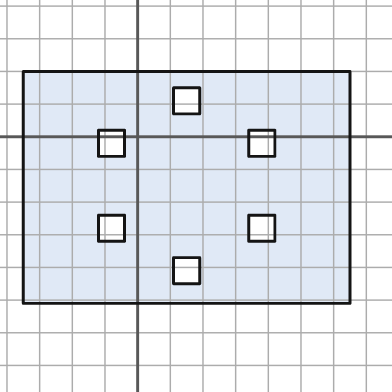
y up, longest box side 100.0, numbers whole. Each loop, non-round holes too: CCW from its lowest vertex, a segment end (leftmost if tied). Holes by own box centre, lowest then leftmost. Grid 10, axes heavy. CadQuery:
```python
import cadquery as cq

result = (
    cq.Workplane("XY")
    .moveTo(-35.0, -51.0)
    .lineTo(65.0, -51.0)
    .lineTo(65.0, 20.0)
    .lineTo(-35.0, 20.0)
    .close()
    .moveTo(11.0, -45.0)
    .lineTo(19.0, -45.0)
    .lineTo(19.0, -37.0)
    .lineTo(11.0, -37.0)
    .close()
    .moveTo(-12.0, -32.0)
    .lineTo(-4.0, -32.0)
    .lineTo(-4.0, -24.0)
    .lineTo(-12.0, -24.0)
    .close()
    .moveTo(34.0, -32.0)
    .lineTo(42.0, -32.0)
    .lineTo(42.0, -24.0)
    .lineTo(34.0, -24.0)
    .close()
    .moveTo(-12.0, -6.0)
    .lineTo(-4.0, -6.0)
    .lineTo(-4.0, 2.0)
    .lineTo(-12.0, 2.0)
    .close()
    .moveTo(34.0, -6.0)
    .lineTo(42.0, -6.0)
    .lineTo(42.0, 2.0)
    .lineTo(34.0, 2.0)
    .close()
    .moveTo(11.0, 7.0)
    .lineTo(19.0, 7.0)
    .lineTo(19.0, 15.0)
    .lineTo(11.0, 15.0)
    .close()
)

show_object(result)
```